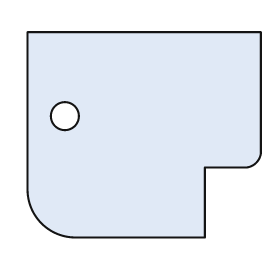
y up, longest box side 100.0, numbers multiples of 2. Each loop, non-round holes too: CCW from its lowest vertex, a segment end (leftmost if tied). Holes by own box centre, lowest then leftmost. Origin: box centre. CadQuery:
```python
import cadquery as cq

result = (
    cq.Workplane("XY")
    .moveTo(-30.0, -44.0)
    .lineTo(26.0, -44.0)
    .lineTo(26.0, -14.0)
    .lineTo(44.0, -14.0)
    .threePointArc((48.0, -12.0), (50.0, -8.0))
    .lineTo(50.0, 44.0)
    .lineTo(-50.0, 44.0)
    .lineTo(-50.0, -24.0)
    .threePointArc((-44.0, -38.0), (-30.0, -44.0))
    .close()
    .moveTo(-34.0, 8.0)
    .circle(6.0)
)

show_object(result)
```